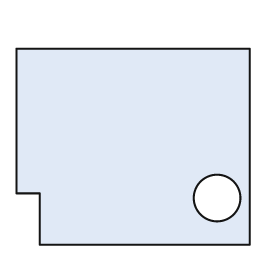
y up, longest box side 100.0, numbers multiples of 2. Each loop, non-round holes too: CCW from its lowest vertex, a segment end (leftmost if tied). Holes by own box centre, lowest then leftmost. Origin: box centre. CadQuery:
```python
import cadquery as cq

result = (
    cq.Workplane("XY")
    .moveTo(-40.0, -42.0)
    .lineTo(50.0, -42.0)
    .lineTo(50.0, 42.0)
    .lineTo(-50.0, 42.0)
    .lineTo(-50.0, -20.0)
    .lineTo(-40.0, -20.0)
    .close()
    .moveTo(36.0, -22.0)
    .circle(10.0)
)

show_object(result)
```